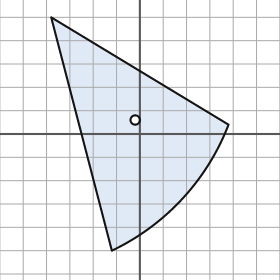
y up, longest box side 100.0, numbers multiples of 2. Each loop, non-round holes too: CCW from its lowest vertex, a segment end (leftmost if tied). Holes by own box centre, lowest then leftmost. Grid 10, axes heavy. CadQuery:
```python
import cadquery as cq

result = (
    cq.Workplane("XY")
    .moveTo(-12.0, -50.0)
    .threePointArc((18.0, -28.0), (38.0, 4.0))
    .lineTo(-38.0, 50.0)
    .close()
    .moveTo(-2.0, 6.0)
    .circle(2.0)
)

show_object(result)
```